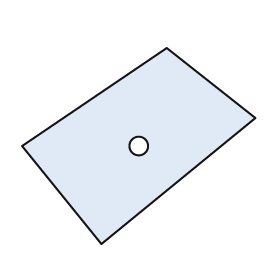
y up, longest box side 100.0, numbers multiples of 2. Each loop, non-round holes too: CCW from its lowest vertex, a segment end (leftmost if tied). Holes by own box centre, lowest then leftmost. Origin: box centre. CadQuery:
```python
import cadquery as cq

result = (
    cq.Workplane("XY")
    .moveTo(-16.0, -42.0)
    .lineTo(50.0, 12.0)
    .lineTo(12.0, 42.0)
    .lineTo(-50.0, 0.0)
    .close()
    .moveTo(0.0, 0.0)
    .circle(4.0)
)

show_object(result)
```